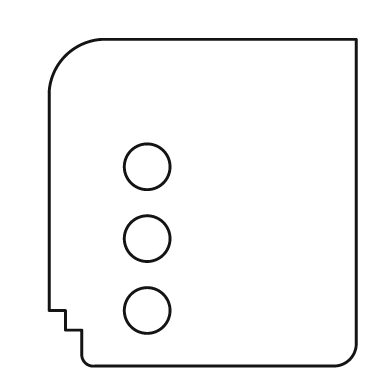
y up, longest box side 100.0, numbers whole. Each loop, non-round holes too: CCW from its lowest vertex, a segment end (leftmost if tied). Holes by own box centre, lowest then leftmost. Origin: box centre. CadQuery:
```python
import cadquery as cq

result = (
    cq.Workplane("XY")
    .moveTo(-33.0, -50.0)
    .lineTo(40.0, -50.0)
    .threePointArc((45.0, -48.0), (47.0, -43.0))
    .lineTo(47.0, 50.0)
    .lineTo(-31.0, 50.0)
    .threePointArc((-42.0, 45.0), (-47.0, 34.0))
    .lineTo(-47.0, -33.0)
    .lineTo(-42.0, -33.0)
    .lineTo(-42.0, -39.0)
    .lineTo(-37.0, -39.0)
    .lineTo(-37.0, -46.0)
    .threePointArc((-36.0, -49.0), (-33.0, -50.0))
    .close()
    .moveTo(-17.0, -33.0)
    .circle(7.0)
    .moveTo(-17.0, -11.0)
    .circle(7.0)
    .moveTo(-17.0, 11.0)
    .circle(7.0)
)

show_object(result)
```